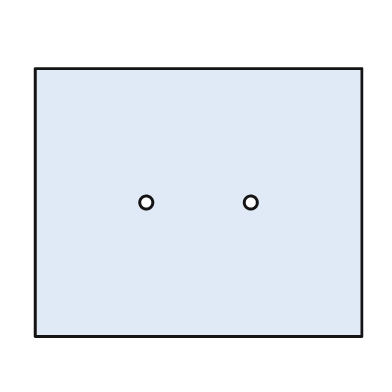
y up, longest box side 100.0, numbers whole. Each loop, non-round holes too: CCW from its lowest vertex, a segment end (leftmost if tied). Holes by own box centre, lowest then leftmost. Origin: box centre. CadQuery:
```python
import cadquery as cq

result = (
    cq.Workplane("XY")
    .moveTo(-50.0, -41.0)
    .lineTo(50.0, -41.0)
    .lineTo(50.0, 41.0)
    .lineTo(-50.0, 41.0)
    .close()
    .moveTo(-16.0, 0.0)
    .circle(2.0)
    .moveTo(16.0, 0.0)
    .circle(2.0)
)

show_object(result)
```